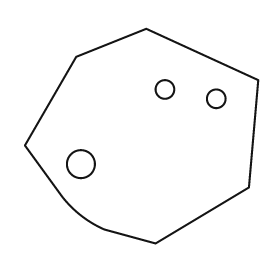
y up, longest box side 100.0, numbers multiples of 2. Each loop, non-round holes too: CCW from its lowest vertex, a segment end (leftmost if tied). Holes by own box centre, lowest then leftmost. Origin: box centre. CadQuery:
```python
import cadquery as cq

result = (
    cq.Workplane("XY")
    .moveTo(6.0, -46.0)
    .lineTo(46.0, -22.0)
    .lineTo(50.0, 24.0)
    .lineTo(2.0, 46.0)
    .lineTo(-28.0, 34.0)
    .lineTo(-50.0, -4.0)
    .lineTo(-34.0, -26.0)
    .threePointArc((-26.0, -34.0), (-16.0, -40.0))
    .close()
    .moveTo(-26.0, -12.0)
    .circle(6.0)
    .moveTo(32.0, 16.0)
    .circle(4.0)
    .moveTo(10.0, 20.0)
    .circle(4.0)
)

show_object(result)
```